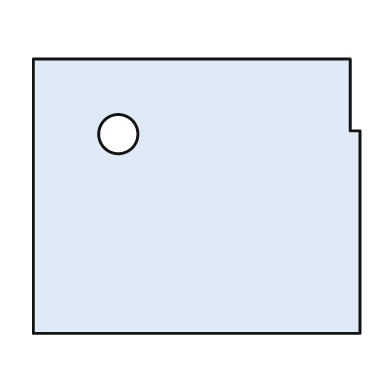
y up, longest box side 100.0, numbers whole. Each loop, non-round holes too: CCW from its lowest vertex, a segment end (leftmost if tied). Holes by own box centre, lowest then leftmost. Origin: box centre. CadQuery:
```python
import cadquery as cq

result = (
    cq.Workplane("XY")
    .moveTo(-50.0, -42.0)
    .lineTo(50.0, -42.0)
    .lineTo(50.0, 20.0)
    .lineTo(47.0, 20.0)
    .lineTo(47.0, 42.0)
    .lineTo(-50.0, 42.0)
    .close()
    .moveTo(-24.0, 19.0)
    .circle(6.0)
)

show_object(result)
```